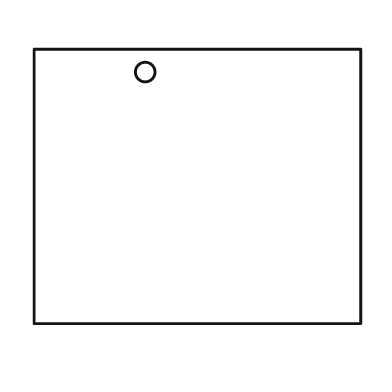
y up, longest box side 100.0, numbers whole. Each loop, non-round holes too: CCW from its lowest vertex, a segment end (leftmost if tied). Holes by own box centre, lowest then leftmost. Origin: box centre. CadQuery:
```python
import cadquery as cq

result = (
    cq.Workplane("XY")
    .moveTo(-50.0, -42.0)
    .lineTo(50.0, -42.0)
    .lineTo(50.0, 42.0)
    .lineTo(-50.0, 42.0)
    .close()
    .moveTo(-16.0, 35.0)
    .circle(3.0)
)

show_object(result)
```